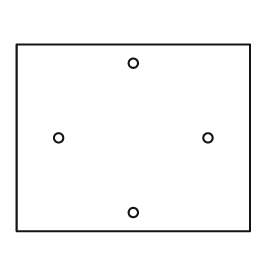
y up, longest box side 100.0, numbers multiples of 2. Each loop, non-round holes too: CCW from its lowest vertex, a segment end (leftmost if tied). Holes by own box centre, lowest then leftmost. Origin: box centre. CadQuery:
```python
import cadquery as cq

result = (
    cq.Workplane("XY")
    .moveTo(-50.0, -40.0)
    .lineTo(50.0, -40.0)
    .lineTo(50.0, 40.0)
    .lineTo(-50.0, 40.0)
    .close()
    .moveTo(0.0, -32.0)
    .circle(2.0)
    .moveTo(-32.0, 0.0)
    .circle(2.0)
    .moveTo(32.0, 0.0)
    .circle(2.0)
    .moveTo(0.0, 32.0)
    .circle(2.0)
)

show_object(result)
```